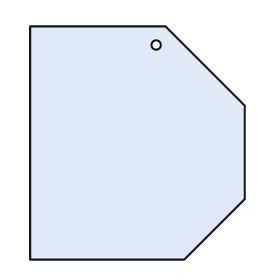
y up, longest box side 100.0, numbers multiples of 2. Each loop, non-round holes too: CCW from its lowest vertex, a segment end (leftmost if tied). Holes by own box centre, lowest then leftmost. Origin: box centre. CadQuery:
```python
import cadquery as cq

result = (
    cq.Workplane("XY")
    .moveTo(-46.0, -50.0)
    .lineTo(20.0, -50.0)
    .lineTo(46.0, -24.0)
    .lineTo(46.0, 16.0)
    .lineTo(12.0, 50.0)
    .lineTo(-46.0, 50.0)
    .close()
    .moveTo(8.0, 42.0)
    .circle(2.0)
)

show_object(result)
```